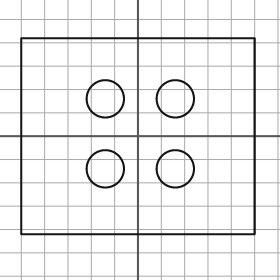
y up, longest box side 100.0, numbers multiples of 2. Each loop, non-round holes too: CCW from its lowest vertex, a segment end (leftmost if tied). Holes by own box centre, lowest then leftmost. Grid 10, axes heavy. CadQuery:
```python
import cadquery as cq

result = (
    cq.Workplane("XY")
    .moveTo(-50.0, -42.0)
    .lineTo(50.0, -42.0)
    .lineTo(50.0, 42.0)
    .lineTo(-50.0, 42.0)
    .close()
    .moveTo(-14.0, -14.0)
    .circle(8.0)
    .moveTo(16.0, -14.0)
    .circle(8.0)
    .moveTo(-14.0, 16.0)
    .circle(8.0)
    .moveTo(16.0, 16.0)
    .circle(8.0)
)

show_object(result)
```